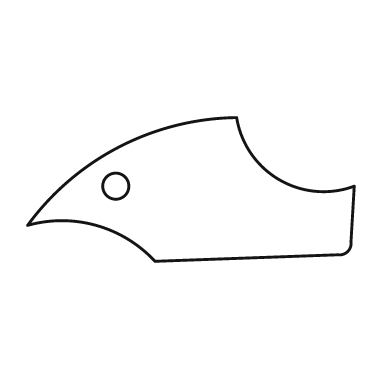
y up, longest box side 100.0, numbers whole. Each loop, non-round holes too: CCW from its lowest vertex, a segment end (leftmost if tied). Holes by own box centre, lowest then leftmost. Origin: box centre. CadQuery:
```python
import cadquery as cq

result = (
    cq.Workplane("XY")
    .moveTo(-11.0, -22.0)
    .lineTo(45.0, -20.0)
    .threePointArc((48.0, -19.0), (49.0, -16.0))
    .lineTo(50.0, 1.0)
    .threePointArc((27.0, 3.0), (14.0, 22.0))
    .threePointArc((-22.0, 13.0), (-50.0, -11.0))
    .threePointArc((-29.0, -11.0), (-11.0, -22.0))
    .close()
    .moveTo(-23.0, 1.0)
    .circle(4.0)
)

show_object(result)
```